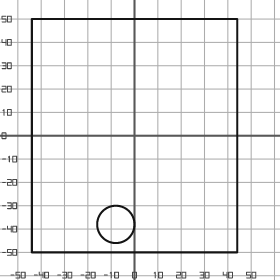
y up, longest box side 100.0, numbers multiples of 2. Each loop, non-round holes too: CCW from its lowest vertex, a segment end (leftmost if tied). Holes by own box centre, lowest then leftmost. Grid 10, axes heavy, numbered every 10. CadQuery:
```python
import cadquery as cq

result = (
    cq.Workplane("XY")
    .moveTo(-44.0, -50.0)
    .lineTo(44.0, -50.0)
    .lineTo(44.0, 50.0)
    .lineTo(-44.0, 50.0)
    .close()
    .moveTo(-8.0, -38.0)
    .circle(8.0)
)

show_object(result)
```